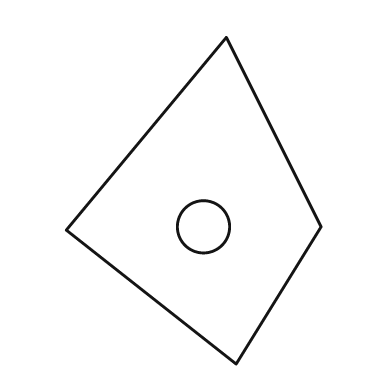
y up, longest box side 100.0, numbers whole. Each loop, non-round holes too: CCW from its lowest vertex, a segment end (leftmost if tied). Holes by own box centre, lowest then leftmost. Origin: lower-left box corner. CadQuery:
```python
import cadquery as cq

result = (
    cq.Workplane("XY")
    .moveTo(52.0, 0.0)
    .lineTo(78.0, 42.0)
    .lineTo(49.0, 100.0)
    .lineTo(0.0, 41.0)
    .close()
    .moveTo(42.0, 42.0)
    .circle(8.0)
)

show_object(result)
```